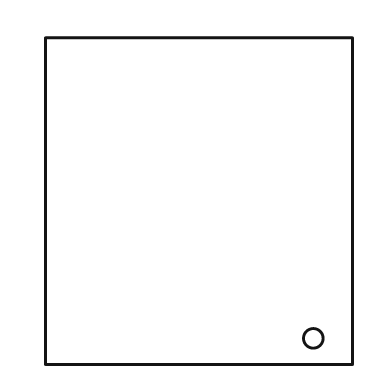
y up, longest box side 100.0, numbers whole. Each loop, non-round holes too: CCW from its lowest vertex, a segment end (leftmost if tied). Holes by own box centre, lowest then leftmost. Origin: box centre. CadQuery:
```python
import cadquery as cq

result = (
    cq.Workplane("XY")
    .moveTo(-47.0, -50.0)
    .lineTo(47.0, -50.0)
    .lineTo(47.0, 50.0)
    .lineTo(-47.0, 50.0)
    .close()
    .moveTo(35.0, -42.0)
    .circle(3.0)
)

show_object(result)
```